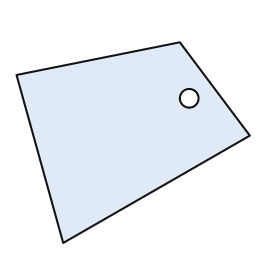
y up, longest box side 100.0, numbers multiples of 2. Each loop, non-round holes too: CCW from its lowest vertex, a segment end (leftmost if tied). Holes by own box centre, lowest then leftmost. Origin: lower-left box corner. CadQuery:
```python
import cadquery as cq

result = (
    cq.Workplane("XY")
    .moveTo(20.0, 0.0)
    .lineTo(100.0, 46.0)
    .lineTo(70.0, 86.0)
    .lineTo(0.0, 72.0)
    .close()
    .moveTo(74.0, 62.0)
    .circle(4.0)
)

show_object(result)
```